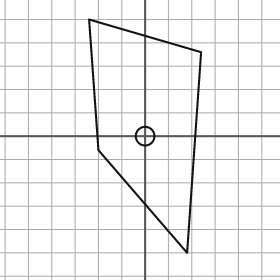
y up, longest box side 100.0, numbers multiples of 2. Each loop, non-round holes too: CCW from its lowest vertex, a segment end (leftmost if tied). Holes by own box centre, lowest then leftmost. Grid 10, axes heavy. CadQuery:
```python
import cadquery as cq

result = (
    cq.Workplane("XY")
    .moveTo(18.0, -50.0)
    .lineTo(24.0, 36.0)
    .lineTo(-24.0, 50.0)
    .lineTo(-20.0, -6.0)
    .close()
    .moveTo(0.0, 0.0)
    .circle(4.0)
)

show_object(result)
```